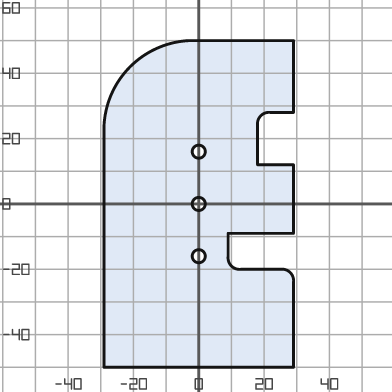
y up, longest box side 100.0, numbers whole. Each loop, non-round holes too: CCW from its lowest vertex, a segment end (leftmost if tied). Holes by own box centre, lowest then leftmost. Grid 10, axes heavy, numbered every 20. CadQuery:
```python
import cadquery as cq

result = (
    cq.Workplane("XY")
    .moveTo(-29.0, -50.0)
    .lineTo(29.0, -50.0)
    .lineTo(29.0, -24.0)
    .threePointArc((28.0, -21.0), (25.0, -20.0))
    .lineTo(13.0, -20.0)
    .threePointArc((10.0, -19.0), (9.0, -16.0))
    .lineTo(9.0, -9.0)
    .lineTo(29.0, -9.0)
    .lineTo(29.0, 12.0)
    .lineTo(18.0, 12.0)
    .lineTo(18.0, 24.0)
    .threePointArc((19.0, 27.0), (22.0, 28.0))
    .lineTo(29.0, 28.0)
    .lineTo(29.0, 50.0)
    .lineTo(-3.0, 50.0)
    .threePointArc((-21.0, 42.0), (-29.0, 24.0))
    .close()
    .moveTo(0.0, -16.0)
    .circle(2.0)
    .moveTo(0.0, 0.0)
    .circle(2.0)
    .moveTo(0.0, 16.0)
    .circle(2.0)
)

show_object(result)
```